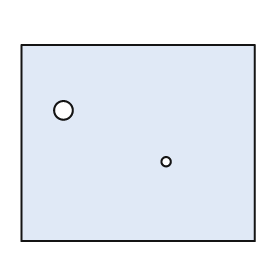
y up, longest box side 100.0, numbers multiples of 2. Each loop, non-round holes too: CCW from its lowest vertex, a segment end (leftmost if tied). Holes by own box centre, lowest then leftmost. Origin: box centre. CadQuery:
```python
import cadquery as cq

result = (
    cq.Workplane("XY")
    .moveTo(-50.0, -42.0)
    .lineTo(50.0, -42.0)
    .lineTo(50.0, 42.0)
    .lineTo(-50.0, 42.0)
    .close()
    .moveTo(12.0, -8.0)
    .circle(2.0)
    .moveTo(-32.0, 14.0)
    .circle(4.0)
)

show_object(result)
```